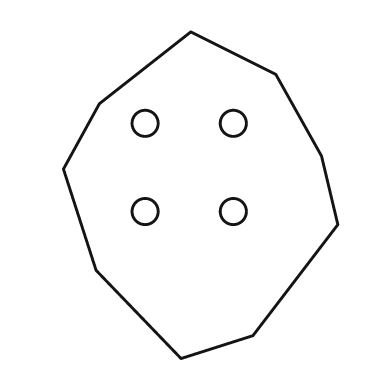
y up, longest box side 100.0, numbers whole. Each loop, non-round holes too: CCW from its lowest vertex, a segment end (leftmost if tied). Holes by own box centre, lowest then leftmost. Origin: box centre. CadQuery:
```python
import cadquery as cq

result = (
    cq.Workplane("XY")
    .moveTo(-6.0, -50.0)
    .lineTo(16.0, -43.0)
    .lineTo(42.0, -9.0)
    .lineTo(37.0, 12.0)
    .lineTo(23.0, 37.0)
    .lineTo(-3.0, 50.0)
    .lineTo(-31.0, 28.0)
    .lineTo(-42.0, 8.0)
    .lineTo(-32.0, -23.0)
    .close()
    .moveTo(-17.0, -5.0)
    .circle(4.0)
    .moveTo(10.0, -5.0)
    .circle(4.0)
    .moveTo(-17.0, 22.0)
    .circle(4.0)
    .moveTo(10.0, 22.0)
    .circle(4.0)
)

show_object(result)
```